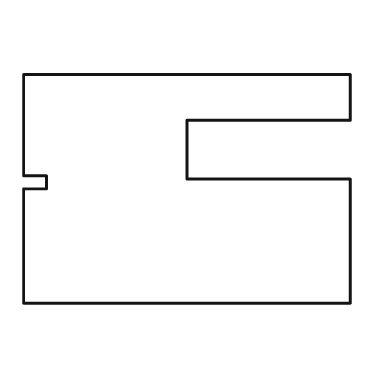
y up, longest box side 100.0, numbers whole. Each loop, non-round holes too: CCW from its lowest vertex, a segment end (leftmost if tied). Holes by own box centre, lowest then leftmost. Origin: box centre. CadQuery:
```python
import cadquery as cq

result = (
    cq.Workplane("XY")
    .moveTo(-50.0, -35.0)
    .lineTo(50.0, -35.0)
    .lineTo(50.0, 3.0)
    .lineTo(0.0, 3.0)
    .lineTo(0.0, 21.0)
    .lineTo(50.0, 21.0)
    .lineTo(50.0, 35.0)
    .lineTo(-50.0, 35.0)
    .lineTo(-50.0, 4.0)
    .lineTo(-43.0, 4.0)
    .lineTo(-43.0, 0.0)
    .lineTo(-50.0, 0.0)
    .close()
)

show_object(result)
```